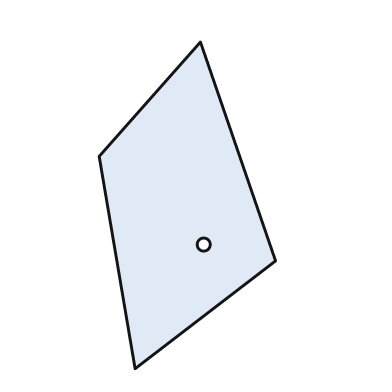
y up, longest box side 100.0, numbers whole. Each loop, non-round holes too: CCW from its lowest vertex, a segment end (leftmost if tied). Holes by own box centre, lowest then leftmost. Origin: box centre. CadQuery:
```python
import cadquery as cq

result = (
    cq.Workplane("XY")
    .moveTo(-16.0, -50.0)
    .lineTo(27.0, -17.0)
    .lineTo(4.0, 50.0)
    .lineTo(-27.0, 15.0)
    .close()
    .moveTo(5.0, -12.0)
    .circle(2.0)
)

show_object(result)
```